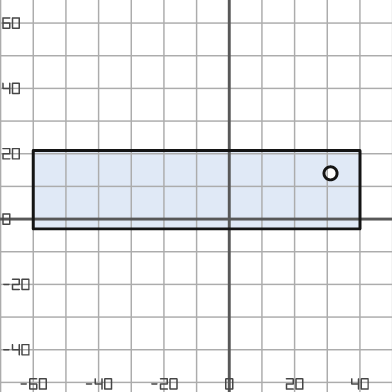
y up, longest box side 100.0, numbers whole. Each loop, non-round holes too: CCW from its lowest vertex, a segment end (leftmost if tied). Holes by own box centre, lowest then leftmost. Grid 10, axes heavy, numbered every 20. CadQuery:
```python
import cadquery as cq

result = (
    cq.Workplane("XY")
    .moveTo(-60.0, -3.0)
    .lineTo(40.0, -3.0)
    .lineTo(40.0, 21.0)
    .lineTo(-60.0, 21.0)
    .close()
    .moveTo(31.0, 14.0)
    .circle(2.0)
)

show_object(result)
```